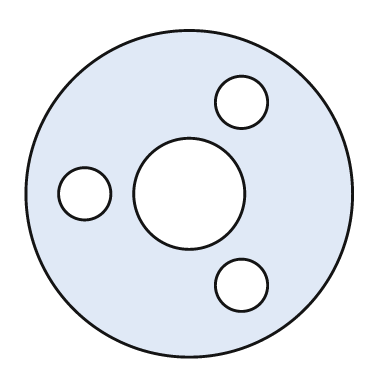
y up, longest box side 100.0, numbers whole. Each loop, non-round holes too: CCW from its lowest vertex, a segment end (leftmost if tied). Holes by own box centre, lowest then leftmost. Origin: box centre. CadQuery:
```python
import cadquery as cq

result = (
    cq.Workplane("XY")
    .moveTo(0.0, 0.0)
    .circle(50.0)
    .moveTo(16.0, -28.0)
    .circle(8.0)
    .moveTo(-32.0, 0.0)
    .circle(8.0)
    .moveTo(0.0, 0.0)
    .circle(17.0)
    .moveTo(16.0, 28.0)
    .circle(8.0)
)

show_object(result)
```